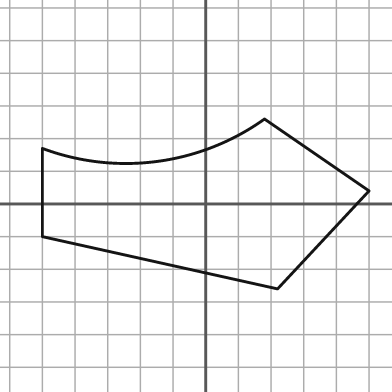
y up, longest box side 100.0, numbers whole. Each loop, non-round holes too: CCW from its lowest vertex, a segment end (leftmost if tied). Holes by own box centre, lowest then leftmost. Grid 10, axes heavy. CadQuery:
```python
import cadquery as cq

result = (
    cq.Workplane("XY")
    .moveTo(22.0, -26.0)
    .lineTo(50.0, 4.0)
    .lineTo(18.0, 26.0)
    .threePointArc((-15.0, 13.0), (-50.0, 17.0))
    .lineTo(-50.0, -10.0)
    .close()
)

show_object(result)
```